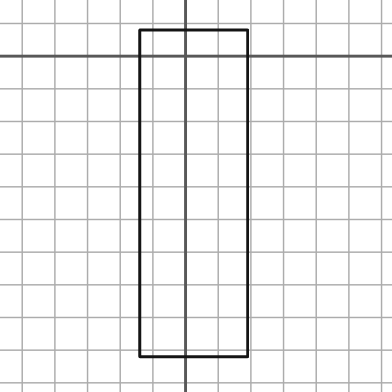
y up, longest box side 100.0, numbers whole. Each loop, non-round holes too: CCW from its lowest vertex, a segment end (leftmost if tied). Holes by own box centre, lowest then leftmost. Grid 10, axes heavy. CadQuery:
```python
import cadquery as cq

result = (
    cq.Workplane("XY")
    .moveTo(-14.0, -92.0)
    .lineTo(19.0, -92.0)
    .lineTo(19.0, 8.0)
    .lineTo(-14.0, 8.0)
    .close()
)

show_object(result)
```